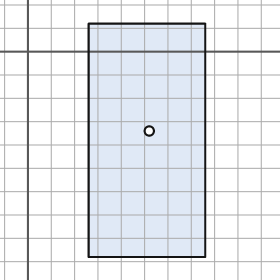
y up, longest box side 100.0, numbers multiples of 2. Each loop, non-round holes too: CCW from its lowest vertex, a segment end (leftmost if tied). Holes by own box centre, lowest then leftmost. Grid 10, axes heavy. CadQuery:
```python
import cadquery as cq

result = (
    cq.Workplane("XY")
    .moveTo(26.0, -88.0)
    .lineTo(76.0, -88.0)
    .lineTo(76.0, 12.0)
    .lineTo(26.0, 12.0)
    .close()
    .moveTo(52.0, -34.0)
    .circle(2.0)
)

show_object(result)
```